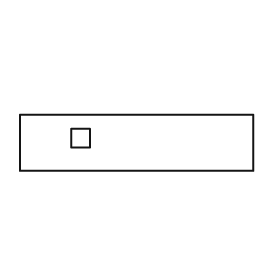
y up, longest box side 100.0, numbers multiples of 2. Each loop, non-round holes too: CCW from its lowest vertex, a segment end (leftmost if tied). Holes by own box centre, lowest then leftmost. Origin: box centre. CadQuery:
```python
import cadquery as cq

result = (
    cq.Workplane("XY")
    .moveTo(-50.0, -12.0)
    .lineTo(50.0, -12.0)
    .lineTo(50.0, 12.0)
    .lineTo(-50.0, 12.0)
    .close()
    .moveTo(-28.0, -2.0)
    .lineTo(-20.0, -2.0)
    .lineTo(-20.0, 6.0)
    .lineTo(-28.0, 6.0)
    .close()
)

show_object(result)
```